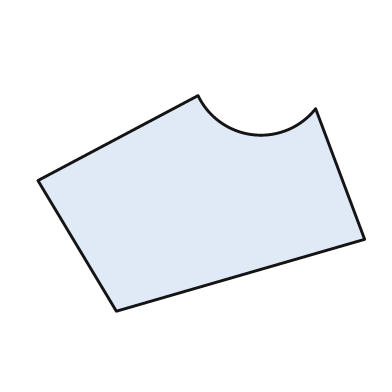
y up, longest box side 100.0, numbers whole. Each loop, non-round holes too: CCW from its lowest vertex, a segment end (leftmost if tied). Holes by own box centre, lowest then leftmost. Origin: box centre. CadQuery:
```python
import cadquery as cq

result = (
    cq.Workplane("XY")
    .moveTo(-26.0, -33.0)
    .lineTo(50.0, -11.0)
    .lineTo(35.0, 29.0)
    .threePointArc((16.0, 21.0), (-1.0, 33.0))
    .lineTo(-50.0, 7.0)
    .close()
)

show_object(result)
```